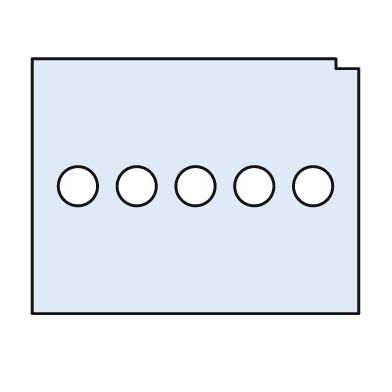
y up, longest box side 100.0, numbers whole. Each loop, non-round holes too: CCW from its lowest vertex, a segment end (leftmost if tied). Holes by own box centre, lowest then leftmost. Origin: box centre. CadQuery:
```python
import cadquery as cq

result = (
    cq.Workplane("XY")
    .moveTo(-50.0, -39.0)
    .lineTo(50.0, -39.0)
    .lineTo(50.0, 36.0)
    .lineTo(43.0, 36.0)
    .lineTo(43.0, 39.0)
    .lineTo(-50.0, 39.0)
    .close()
    .moveTo(-36.0, 0.0)
    .circle(6.0)
    .moveTo(-18.0, 0.0)
    .circle(6.0)
    .moveTo(0.0, 0.0)
    .circle(6.0)
    .moveTo(18.0, 0.0)
    .circle(6.0)
    .moveTo(36.0, 0.0)
    .circle(6.0)
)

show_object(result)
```